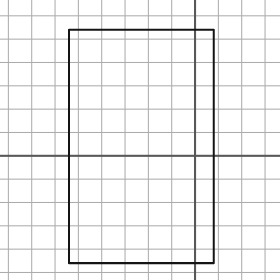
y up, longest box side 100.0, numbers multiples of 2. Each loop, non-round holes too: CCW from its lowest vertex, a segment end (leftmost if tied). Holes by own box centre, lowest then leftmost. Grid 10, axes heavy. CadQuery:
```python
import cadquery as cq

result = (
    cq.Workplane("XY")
    .moveTo(-54.0, -46.0)
    .lineTo(8.0, -46.0)
    .lineTo(8.0, 54.0)
    .lineTo(-54.0, 54.0)
    .close()
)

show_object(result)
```